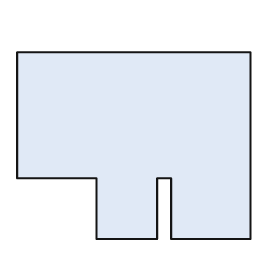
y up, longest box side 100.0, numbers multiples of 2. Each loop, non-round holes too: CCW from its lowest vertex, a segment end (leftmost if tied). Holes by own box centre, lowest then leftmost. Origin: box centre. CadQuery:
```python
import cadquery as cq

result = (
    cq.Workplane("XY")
    .moveTo(-16.0, -40.0)
    .lineTo(10.0, -40.0)
    .lineTo(10.0, -14.0)
    .lineTo(16.0, -14.0)
    .lineTo(16.0, -40.0)
    .lineTo(50.0, -40.0)
    .lineTo(50.0, 40.0)
    .lineTo(-50.0, 40.0)
    .lineTo(-50.0, -14.0)
    .lineTo(-16.0, -14.0)
    .close()
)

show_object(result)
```